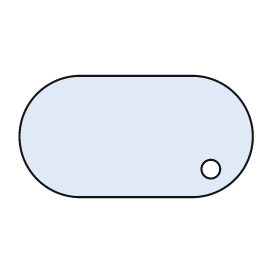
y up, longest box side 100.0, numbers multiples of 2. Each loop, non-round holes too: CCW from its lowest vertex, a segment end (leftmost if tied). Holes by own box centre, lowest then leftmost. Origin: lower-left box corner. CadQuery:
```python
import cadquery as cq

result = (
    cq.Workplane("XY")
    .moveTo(26.0, 0.0)
    .lineTo(74.0, 0.0)
    .threePointArc((100.0, 26.0), (74.0, 52.0))
    .lineTo(26.0, 52.0)
    .threePointArc((0.0, 26.0), (26.0, 0.0))
    .close()
    .moveTo(82.0, 12.0)
    .circle(4.0)
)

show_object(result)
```